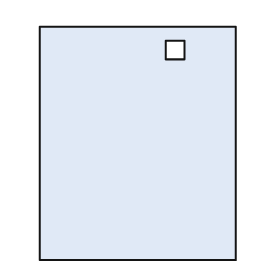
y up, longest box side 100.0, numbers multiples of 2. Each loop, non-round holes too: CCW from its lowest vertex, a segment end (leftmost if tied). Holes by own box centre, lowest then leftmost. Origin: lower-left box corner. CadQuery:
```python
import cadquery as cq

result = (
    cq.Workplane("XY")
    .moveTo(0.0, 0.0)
    .lineTo(84.0, 0.0)
    .lineTo(84.0, 100.0)
    .lineTo(0.0, 100.0)
    .close()
    .moveTo(54.0, 86.0)
    .lineTo(62.0, 86.0)
    .lineTo(62.0, 94.0)
    .lineTo(54.0, 94.0)
    .close()
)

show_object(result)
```